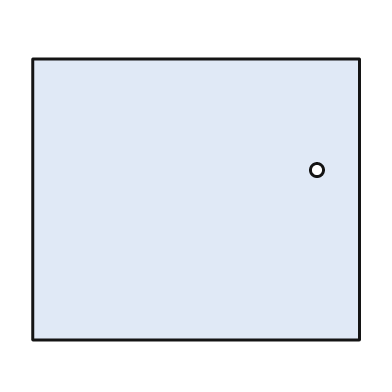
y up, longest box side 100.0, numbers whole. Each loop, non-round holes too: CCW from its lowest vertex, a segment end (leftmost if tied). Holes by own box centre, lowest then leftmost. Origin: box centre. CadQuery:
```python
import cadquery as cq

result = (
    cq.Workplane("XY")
    .moveTo(-50.0, -43.0)
    .lineTo(50.0, -43.0)
    .lineTo(50.0, 43.0)
    .lineTo(-50.0, 43.0)
    .close()
    .moveTo(37.0, 9.0)
    .circle(2.0)
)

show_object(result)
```